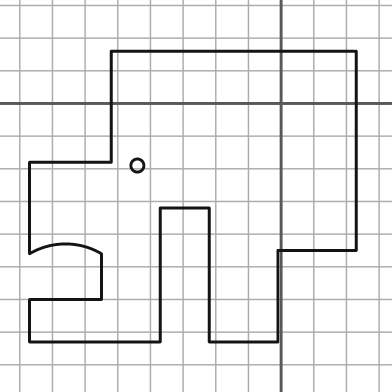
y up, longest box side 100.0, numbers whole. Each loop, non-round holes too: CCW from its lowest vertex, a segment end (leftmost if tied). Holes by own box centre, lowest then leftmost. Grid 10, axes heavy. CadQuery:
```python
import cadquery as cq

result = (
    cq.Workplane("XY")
    .moveTo(-77.0, -73.0)
    .lineTo(-37.0, -73.0)
    .lineTo(-37.0, -32.0)
    .lineTo(-22.0, -32.0)
    .lineTo(-22.0, -73.0)
    .lineTo(-1.0, -73.0)
    .lineTo(-1.0, -45.0)
    .lineTo(23.0, -45.0)
    .lineTo(23.0, 16.0)
    .lineTo(-52.0, 16.0)
    .lineTo(-52.0, -18.0)
    .lineTo(-77.0, -18.0)
    .lineTo(-77.0, -46.0)
    .threePointArc((-66.0, -43.0), (-55.0, -46.0))
    .lineTo(-55.0, -60.0)
    .lineTo(-77.0, -60.0)
    .close()
    .moveTo(-44.0, -19.0)
    .circle(2.0)
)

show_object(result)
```